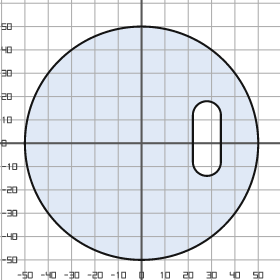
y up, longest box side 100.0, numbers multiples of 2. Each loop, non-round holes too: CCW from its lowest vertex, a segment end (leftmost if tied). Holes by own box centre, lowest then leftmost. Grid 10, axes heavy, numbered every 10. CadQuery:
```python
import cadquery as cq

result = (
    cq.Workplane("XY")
    .moveTo(0.0, 0.0)
    .circle(50.0)
    .moveTo(22.0, -8.0)
    .threePointArc((28.0, -14.0), (34.0, -8.0))
    .lineTo(34.0, 12.0)
    .threePointArc((28.0, 18.0), (22.0, 12.0))
    .close()
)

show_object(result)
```